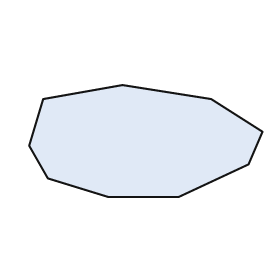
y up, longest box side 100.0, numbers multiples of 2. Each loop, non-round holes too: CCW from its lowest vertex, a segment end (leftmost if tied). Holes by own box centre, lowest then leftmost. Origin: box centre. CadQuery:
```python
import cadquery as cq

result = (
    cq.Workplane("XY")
    .moveTo(-16.0, -24.0)
    .lineTo(14.0, -24.0)
    .lineTo(44.0, -10.0)
    .lineTo(50.0, 4.0)
    .lineTo(28.0, 18.0)
    .lineTo(-10.0, 24.0)
    .lineTo(-44.0, 18.0)
    .lineTo(-50.0, -2.0)
    .lineTo(-42.0, -16.0)
    .close()
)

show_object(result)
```